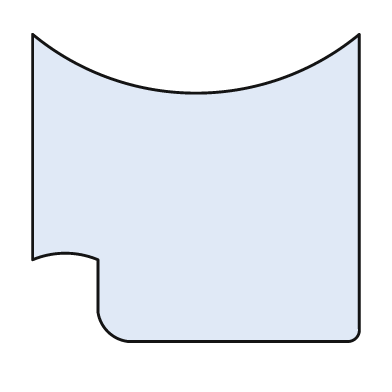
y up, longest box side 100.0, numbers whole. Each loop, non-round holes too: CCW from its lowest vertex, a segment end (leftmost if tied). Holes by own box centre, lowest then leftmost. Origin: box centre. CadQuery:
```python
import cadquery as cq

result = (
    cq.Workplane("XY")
    .moveTo(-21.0, -47.0)
    .lineTo(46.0, -47.0)
    .threePointArc((49.0, -46.0), (50.0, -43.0))
    .lineTo(50.0, 47.0)
    .threePointArc((0.0, 29.0), (-50.0, 47.0))
    .lineTo(-50.0, -22.0)
    .threePointArc((-40.0, -20.0), (-30.0, -22.0))
    .lineTo(-30.0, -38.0)
    .threePointArc((-27.0, -44.0), (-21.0, -47.0))
    .close()
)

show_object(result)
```